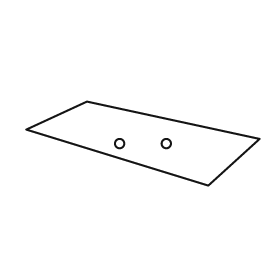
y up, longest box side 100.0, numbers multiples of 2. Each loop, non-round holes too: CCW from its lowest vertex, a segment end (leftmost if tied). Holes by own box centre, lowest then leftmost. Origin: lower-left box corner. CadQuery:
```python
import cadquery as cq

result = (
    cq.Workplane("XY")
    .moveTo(78.0, 0.0)
    .lineTo(100.0, 20.0)
    .lineTo(26.0, 36.0)
    .lineTo(0.0, 24.0)
    .close()
    .moveTo(40.0, 18.0)
    .circle(2.0)
    .moveTo(60.0, 18.0)
    .circle(2.0)
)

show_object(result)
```